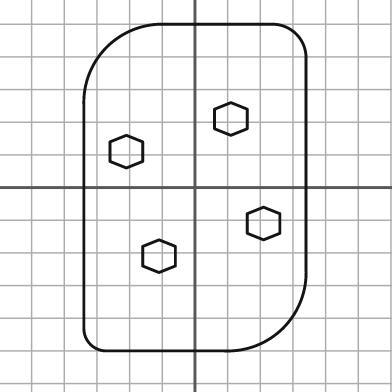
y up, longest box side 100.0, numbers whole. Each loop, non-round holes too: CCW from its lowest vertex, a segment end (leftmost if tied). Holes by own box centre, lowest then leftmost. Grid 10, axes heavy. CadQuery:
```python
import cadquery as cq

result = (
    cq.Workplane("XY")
    .moveTo(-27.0, -50.0)
    .lineTo(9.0, -50.0)
    .threePointArc((27.0, -43.0), (34.0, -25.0))
    .lineTo(34.0, 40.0)
    .threePointArc((31.0, 47.0), (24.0, 50.0))
    .lineTo(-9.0, 50.0)
    .threePointArc((-27.0, 43.0), (-34.0, 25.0))
    .lineTo(-34.0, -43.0)
    .threePointArc((-32.0, -48.0), (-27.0, -50.0))
    .close()
    .moveTo(-11.0, -26.0)
    .lineTo(-6.0, -24.0)
    .lineTo(-6.0, -18.0)
    .lineTo(-11.0, -16.0)
    .lineTo(-16.0, -18.0)
    .lineTo(-16.0, -24.0)
    .close()
    .moveTo(21.0, -16.0)
    .lineTo(26.0, -14.0)
    .lineTo(26.0, -8.0)
    .lineTo(21.0, -6.0)
    .lineTo(16.0, -8.0)
    .lineTo(16.0, -14.0)
    .close()
    .moveTo(-21.0, 6.0)
    .lineTo(-16.0, 8.0)
    .lineTo(-16.0, 14.0)
    .lineTo(-21.0, 16.0)
    .lineTo(-26.0, 14.0)
    .lineTo(-26.0, 8.0)
    .close()
    .moveTo(11.0, 16.0)
    .lineTo(16.0, 18.0)
    .lineTo(16.0, 24.0)
    .lineTo(11.0, 26.0)
    .lineTo(6.0, 24.0)
    .lineTo(6.0, 18.0)
    .close()
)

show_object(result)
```